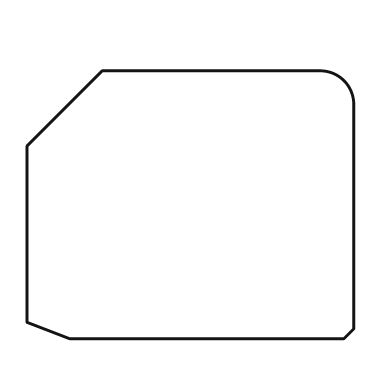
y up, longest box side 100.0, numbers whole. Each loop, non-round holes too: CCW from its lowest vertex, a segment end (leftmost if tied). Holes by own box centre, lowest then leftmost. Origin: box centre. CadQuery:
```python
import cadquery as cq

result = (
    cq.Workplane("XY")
    .moveTo(-37.0, -41.0)
    .lineTo(47.0, -41.0)
    .lineTo(50.0, -38.0)
    .lineTo(50.0, 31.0)
    .threePointArc((47.0, 38.0), (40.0, 41.0))
    .lineTo(-27.0, 41.0)
    .lineTo(-50.0, 18.0)
    .lineTo(-50.0, -36.0)
    .close()
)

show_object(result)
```